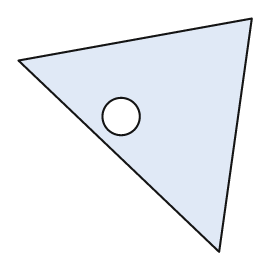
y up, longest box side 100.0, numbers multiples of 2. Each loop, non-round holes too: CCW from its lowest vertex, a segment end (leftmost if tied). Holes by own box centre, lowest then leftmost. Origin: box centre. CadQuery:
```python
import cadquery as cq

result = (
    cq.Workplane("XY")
    .moveTo(36.0, -50.0)
    .lineTo(50.0, 50.0)
    .lineTo(-50.0, 32.0)
    .close()
    .moveTo(-6.0, 8.0)
    .circle(8.0)
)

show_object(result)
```